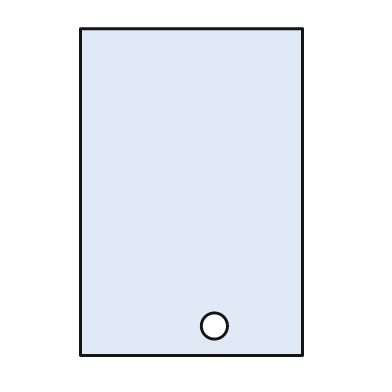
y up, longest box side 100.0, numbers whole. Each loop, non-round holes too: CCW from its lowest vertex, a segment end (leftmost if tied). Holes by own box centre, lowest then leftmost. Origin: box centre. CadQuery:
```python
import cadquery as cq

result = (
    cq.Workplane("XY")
    .moveTo(-34.0, -50.0)
    .lineTo(34.0, -50.0)
    .lineTo(34.0, 50.0)
    .lineTo(-34.0, 50.0)
    .close()
    .moveTo(7.0, -41.0)
    .circle(4.0)
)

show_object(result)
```